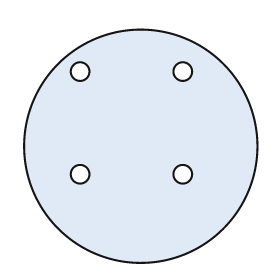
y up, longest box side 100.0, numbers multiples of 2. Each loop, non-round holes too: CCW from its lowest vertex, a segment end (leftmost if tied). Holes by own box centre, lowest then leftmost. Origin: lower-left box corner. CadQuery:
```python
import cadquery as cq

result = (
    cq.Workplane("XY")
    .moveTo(50.0, 50.0)
    .circle(50.0)
    .moveTo(24.0, 38.0)
    .circle(4.0)
    .moveTo(68.0, 38.0)
    .circle(4.0)
    .moveTo(24.0, 82.0)
    .circle(4.0)
    .moveTo(68.0, 82.0)
    .circle(4.0)
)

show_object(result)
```